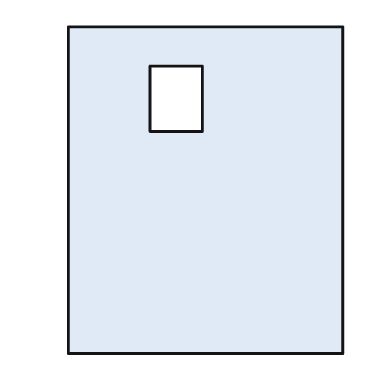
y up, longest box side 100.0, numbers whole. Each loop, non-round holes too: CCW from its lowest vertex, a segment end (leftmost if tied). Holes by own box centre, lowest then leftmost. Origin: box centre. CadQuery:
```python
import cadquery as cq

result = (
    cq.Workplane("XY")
    .moveTo(-42.0, -50.0)
    .lineTo(42.0, -50.0)
    .lineTo(42.0, 50.0)
    .lineTo(-42.0, 50.0)
    .close()
    .moveTo(-17.0, 18.0)
    .lineTo(-1.0, 18.0)
    .lineTo(-1.0, 38.0)
    .lineTo(-17.0, 38.0)
    .close()
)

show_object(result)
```